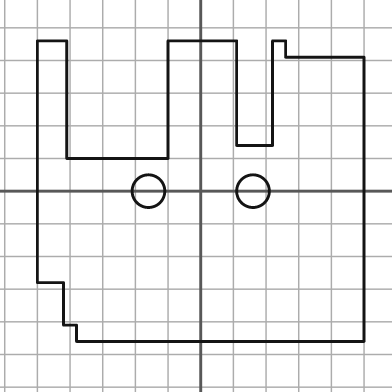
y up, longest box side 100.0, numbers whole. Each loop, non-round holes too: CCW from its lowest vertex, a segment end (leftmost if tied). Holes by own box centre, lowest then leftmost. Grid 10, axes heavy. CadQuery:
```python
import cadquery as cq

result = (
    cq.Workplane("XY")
    .moveTo(-38.0, -46.0)
    .lineTo(50.0, -46.0)
    .lineTo(50.0, 41.0)
    .lineTo(26.0, 41.0)
    .lineTo(26.0, 46.0)
    .lineTo(22.0, 46.0)
    .lineTo(22.0, 14.0)
    .lineTo(11.0, 14.0)
    .lineTo(11.0, 46.0)
    .lineTo(-10.0, 46.0)
    .lineTo(-10.0, 10.0)
    .lineTo(-41.0, 10.0)
    .lineTo(-41.0, 46.0)
    .lineTo(-50.0, 46.0)
    .lineTo(-50.0, -28.0)
    .lineTo(-42.0, -28.0)
    .lineTo(-42.0, -41.0)
    .lineTo(-38.0, -41.0)
    .close()
    .moveTo(-16.0, 0.0)
    .circle(5.0)
    .moveTo(16.0, 0.0)
    .circle(5.0)
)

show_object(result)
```